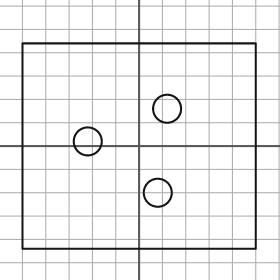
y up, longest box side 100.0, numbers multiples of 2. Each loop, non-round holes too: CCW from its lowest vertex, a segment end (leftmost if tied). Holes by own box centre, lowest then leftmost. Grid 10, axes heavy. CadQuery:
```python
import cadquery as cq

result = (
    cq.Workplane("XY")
    .moveTo(-50.0, -44.0)
    .lineTo(50.0, -44.0)
    .lineTo(50.0, 44.0)
    .lineTo(-50.0, 44.0)
    .close()
    .moveTo(8.0, -20.0)
    .circle(6.0)
    .moveTo(-22.0, 2.0)
    .circle(6.0)
    .moveTo(12.0, 16.0)
    .circle(6.0)
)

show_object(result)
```